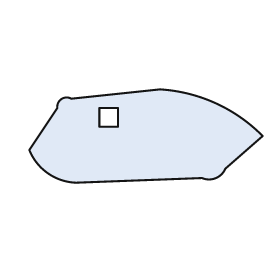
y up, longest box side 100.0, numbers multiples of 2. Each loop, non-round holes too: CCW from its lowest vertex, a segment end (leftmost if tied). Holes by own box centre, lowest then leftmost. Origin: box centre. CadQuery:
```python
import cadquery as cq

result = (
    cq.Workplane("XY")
    .moveTo(-30.0, -20.0)
    .lineTo(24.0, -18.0)
    .threePointArc((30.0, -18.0), (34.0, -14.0))
    .lineTo(50.0, 0.0)
    .threePointArc((30.0, 14.0), (6.0, 20.0))
    .lineTo(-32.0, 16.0)
    .threePointArc((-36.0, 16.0), (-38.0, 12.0))
    .lineTo(-50.0, -6.0)
    .threePointArc((-42.0, -16.0), (-30.0, -20.0))
    .close()
    .moveTo(-20.0, 4.0)
    .lineTo(-12.0, 4.0)
    .lineTo(-12.0, 12.0)
    .lineTo(-20.0, 12.0)
    .close()
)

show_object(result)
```